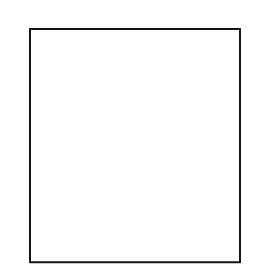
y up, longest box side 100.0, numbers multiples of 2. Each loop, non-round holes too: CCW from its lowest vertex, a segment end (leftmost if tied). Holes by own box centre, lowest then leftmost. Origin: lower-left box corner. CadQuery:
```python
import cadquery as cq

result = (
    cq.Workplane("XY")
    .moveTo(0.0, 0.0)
    .lineTo(90.0, 0.0)
    .lineTo(90.0, 100.0)
    .lineTo(0.0, 100.0)
    .close()
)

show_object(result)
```